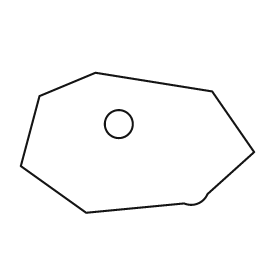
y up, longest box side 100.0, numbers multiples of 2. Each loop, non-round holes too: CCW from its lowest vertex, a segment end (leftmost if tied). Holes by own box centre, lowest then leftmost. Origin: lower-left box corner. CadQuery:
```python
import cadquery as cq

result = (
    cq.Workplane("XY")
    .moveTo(28.0, 0.0)
    .lineTo(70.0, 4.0)
    .threePointArc((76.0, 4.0), (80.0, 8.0))
    .lineTo(100.0, 26.0)
    .lineTo(82.0, 52.0)
    .lineTo(32.0, 60.0)
    .lineTo(8.0, 50.0)
    .lineTo(0.0, 20.0)
    .close()
    .moveTo(42.0, 38.0)
    .circle(6.0)
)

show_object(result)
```